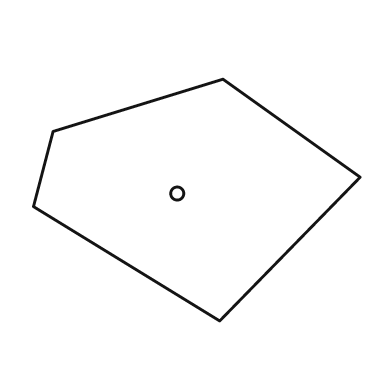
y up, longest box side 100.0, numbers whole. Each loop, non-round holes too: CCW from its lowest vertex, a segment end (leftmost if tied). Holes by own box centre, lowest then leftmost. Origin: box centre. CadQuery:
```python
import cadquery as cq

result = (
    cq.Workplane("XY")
    .moveTo(7.0, -37.0)
    .lineTo(50.0, 7.0)
    .lineTo(8.0, 37.0)
    .lineTo(-44.0, 21.0)
    .lineTo(-50.0, -2.0)
    .close()
    .moveTo(-6.0, 2.0)
    .circle(2.0)
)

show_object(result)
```